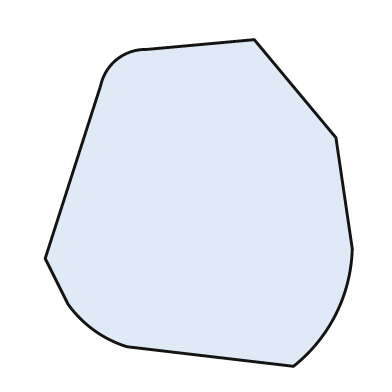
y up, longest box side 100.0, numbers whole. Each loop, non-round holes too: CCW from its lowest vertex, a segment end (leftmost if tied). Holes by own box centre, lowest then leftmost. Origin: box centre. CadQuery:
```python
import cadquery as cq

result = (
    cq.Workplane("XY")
    .moveTo(29.0, -50.0)
    .threePointArc((42.0, -34.0), (47.0, -14.0))
    .lineTo(42.0, 20.0)
    .lineTo(17.0, 50.0)
    .lineTo(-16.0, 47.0)
    .threePointArc((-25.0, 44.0), (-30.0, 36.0))
    .lineTo(-47.0, -17.0)
    .lineTo(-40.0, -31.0)
    .threePointArc((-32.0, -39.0), (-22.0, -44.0))
    .close()
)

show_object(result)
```